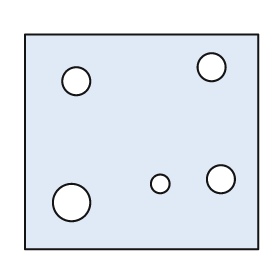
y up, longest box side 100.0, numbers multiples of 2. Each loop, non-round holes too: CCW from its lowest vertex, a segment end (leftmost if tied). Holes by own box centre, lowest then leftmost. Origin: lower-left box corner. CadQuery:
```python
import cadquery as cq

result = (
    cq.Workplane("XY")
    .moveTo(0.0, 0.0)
    .lineTo(100.0, 0.0)
    .lineTo(100.0, 92.0)
    .lineTo(0.0, 92.0)
    .close()
    .moveTo(20.0, 20.0)
    .circle(8.0)
    .moveTo(58.0, 28.0)
    .circle(4.0)
    .moveTo(84.0, 30.0)
    .circle(6.0)
    .moveTo(22.0, 72.0)
    .circle(6.0)
    .moveTo(80.0, 78.0)
    .circle(6.0)
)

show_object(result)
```